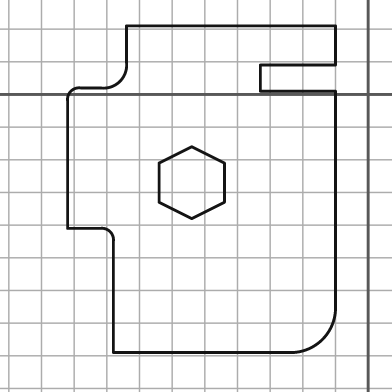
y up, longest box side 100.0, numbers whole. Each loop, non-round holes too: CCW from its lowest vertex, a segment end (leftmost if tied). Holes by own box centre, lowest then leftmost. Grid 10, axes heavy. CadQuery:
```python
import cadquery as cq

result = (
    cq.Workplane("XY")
    .moveTo(-78.0, -79.0)
    .lineTo(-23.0, -79.0)
    .threePointArc((-14.0, -75.0), (-10.0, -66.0))
    .lineTo(-10.0, 1.0)
    .lineTo(-33.0, 1.0)
    .lineTo(-33.0, 9.0)
    .lineTo(-10.0, 9.0)
    .lineTo(-10.0, 21.0)
    .lineTo(-74.0, 21.0)
    .lineTo(-74.0, 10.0)
    .threePointArc((-76.0, 4.0), (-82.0, 2.0))
    .lineTo(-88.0, 2.0)
    .threePointArc((-91.0, 1.0), (-92.0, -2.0))
    .lineTo(-92.0, -41.0)
    .lineTo(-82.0, -41.0)
    .threePointArc((-79.0, -42.0), (-78.0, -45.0))
    .close()
    .moveTo(-54.0, -38.0)
    .lineTo(-44.0, -33.0)
    .lineTo(-44.0, -21.0)
    .lineTo(-54.0, -16.0)
    .lineTo(-64.0, -21.0)
    .lineTo(-64.0, -33.0)
    .close()
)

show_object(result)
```